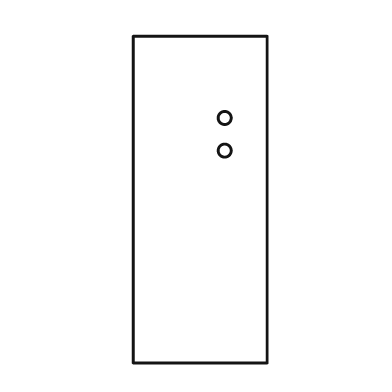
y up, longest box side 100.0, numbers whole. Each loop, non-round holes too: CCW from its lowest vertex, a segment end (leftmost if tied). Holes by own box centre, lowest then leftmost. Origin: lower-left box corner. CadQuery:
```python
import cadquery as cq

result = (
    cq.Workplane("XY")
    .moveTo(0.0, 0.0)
    .lineTo(41.0, 0.0)
    .lineTo(41.0, 100.0)
    .lineTo(0.0, 100.0)
    .close()
    .moveTo(28.0, 65.0)
    .circle(2.0)
    .moveTo(28.0, 75.0)
    .circle(2.0)
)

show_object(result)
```